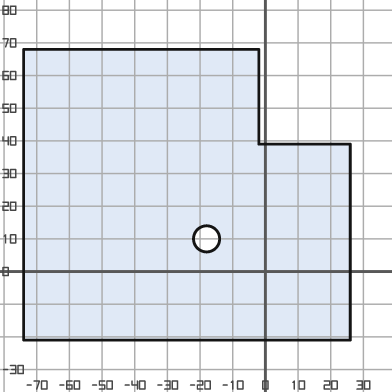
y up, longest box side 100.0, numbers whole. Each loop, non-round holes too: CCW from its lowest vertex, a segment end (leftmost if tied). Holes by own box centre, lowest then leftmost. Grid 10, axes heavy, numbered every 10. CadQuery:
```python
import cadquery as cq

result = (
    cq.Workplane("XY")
    .moveTo(-74.0, -21.0)
    .lineTo(26.0, -21.0)
    .lineTo(26.0, 39.0)
    .lineTo(-2.0, 39.0)
    .lineTo(-2.0, 68.0)
    .lineTo(-74.0, 68.0)
    .close()
    .moveTo(-18.0, 10.0)
    .circle(4.0)
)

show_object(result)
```